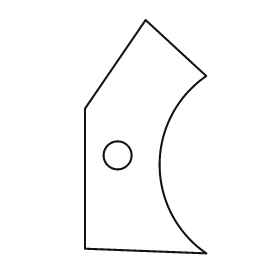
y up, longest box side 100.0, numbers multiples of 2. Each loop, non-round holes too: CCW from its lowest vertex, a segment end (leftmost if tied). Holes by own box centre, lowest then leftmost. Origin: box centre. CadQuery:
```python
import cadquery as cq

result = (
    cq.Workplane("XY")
    .moveTo(26.0, -50.0)
    .threePointArc((6.0, -12.0), (26.0, 26.0))
    .lineTo(0.0, 50.0)
    .lineTo(-26.0, 12.0)
    .lineTo(-26.0, -48.0)
    .close()
    .moveTo(-12.0, -8.0)
    .circle(6.0)
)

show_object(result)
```